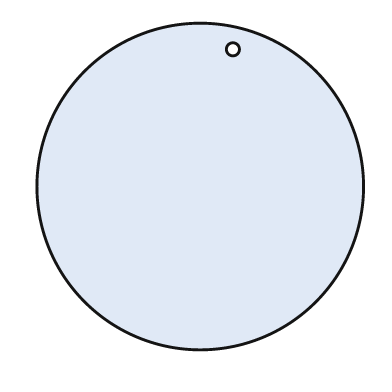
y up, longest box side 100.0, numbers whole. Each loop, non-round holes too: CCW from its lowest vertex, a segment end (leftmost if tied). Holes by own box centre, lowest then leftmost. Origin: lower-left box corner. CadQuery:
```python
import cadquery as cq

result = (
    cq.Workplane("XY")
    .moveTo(50.0, 50.0)
    .circle(50.0)
    .moveTo(60.0, 92.0)
    .circle(2.0)
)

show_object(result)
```